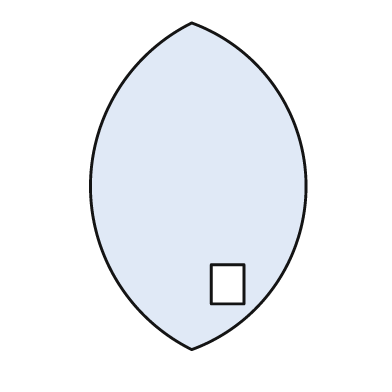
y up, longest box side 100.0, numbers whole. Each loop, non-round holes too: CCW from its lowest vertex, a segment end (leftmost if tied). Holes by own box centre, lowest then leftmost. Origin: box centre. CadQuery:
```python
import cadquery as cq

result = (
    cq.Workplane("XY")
    .moveTo(-2.0, -50.0)
    .threePointArc((33.0, 0.0), (-2.0, 50.0))
    .threePointArc((-33.0, 0.0), (-2.0, -50.0))
    .close()
    .moveTo(4.0, -36.0)
    .lineTo(14.0, -36.0)
    .lineTo(14.0, -24.0)
    .lineTo(4.0, -24.0)
    .close()
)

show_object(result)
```